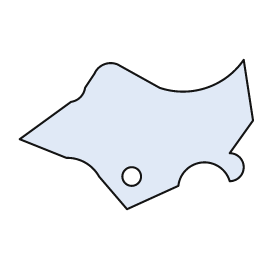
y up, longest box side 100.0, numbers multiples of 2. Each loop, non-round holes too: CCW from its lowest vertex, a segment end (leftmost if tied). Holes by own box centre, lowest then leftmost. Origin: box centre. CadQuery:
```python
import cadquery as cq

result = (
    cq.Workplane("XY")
    .moveTo(-4.0, -32.0)
    .lineTo(18.0, -22.0)
    .threePointArc((28.0, -12.0), (40.0, -20.0))
    .threePointArc((46.0, -14.0), (40.0, -8.0))
    .lineTo(50.0, 6.0)
    .lineTo(46.0, 32.0)
    .threePointArc((30.0, 20.0), (10.0, 20.0))
    .lineTo(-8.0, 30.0)
    .threePointArc((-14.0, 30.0), (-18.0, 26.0))
    .lineTo(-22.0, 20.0)
    .threePointArc((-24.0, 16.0), (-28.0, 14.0))
    .lineTo(-50.0, -2.0)
    .lineTo(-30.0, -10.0)
    .threePointArc((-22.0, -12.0), (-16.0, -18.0))
    .close()
    .moveTo(-2.0, -18.0)
    .circle(4.0)
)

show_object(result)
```